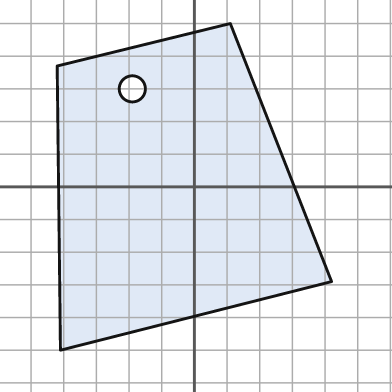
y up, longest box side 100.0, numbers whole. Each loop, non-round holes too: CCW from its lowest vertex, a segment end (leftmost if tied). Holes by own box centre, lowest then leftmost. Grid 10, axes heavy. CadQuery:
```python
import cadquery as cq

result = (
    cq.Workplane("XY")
    .moveTo(-41.0, -50.0)
    .lineTo(42.0, -29.0)
    .lineTo(11.0, 50.0)
    .lineTo(-42.0, 37.0)
    .close()
    .moveTo(-19.0, 30.0)
    .circle(4.0)
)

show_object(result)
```